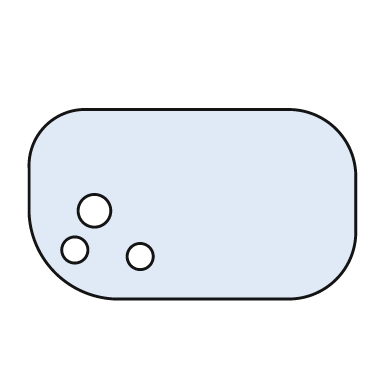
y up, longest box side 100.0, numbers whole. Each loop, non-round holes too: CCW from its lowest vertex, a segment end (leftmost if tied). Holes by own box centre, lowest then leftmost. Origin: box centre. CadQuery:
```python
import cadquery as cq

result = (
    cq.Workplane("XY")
    .moveTo(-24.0, -29.0)
    .lineTo(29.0, -29.0)
    .threePointArc((44.0, -23.0), (50.0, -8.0))
    .lineTo(50.0, 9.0)
    .threePointArc((44.0, 23.0), (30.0, 29.0))
    .lineTo(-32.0, 29.0)
    .threePointArc((-45.0, 24.0), (-50.0, 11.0))
    .lineTo(-50.0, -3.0)
    .threePointArc((-42.0, -21.0), (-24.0, -29.0))
    .close()
    .moveTo(-16.0, -16.0)
    .circle(4.0)
    .moveTo(-36.0, -14.0)
    .circle(4.0)
    .moveTo(-30.0, -2.0)
    .circle(5.0)
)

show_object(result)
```